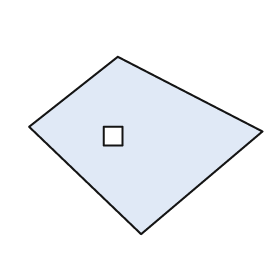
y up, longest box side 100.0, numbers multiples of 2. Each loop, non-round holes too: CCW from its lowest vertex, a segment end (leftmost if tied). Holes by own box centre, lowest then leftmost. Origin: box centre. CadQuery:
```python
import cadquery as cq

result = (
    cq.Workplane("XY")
    .moveTo(-2.0, -38.0)
    .lineTo(50.0, 6.0)
    .lineTo(-12.0, 38.0)
    .lineTo(-50.0, 8.0)
    .close()
    .moveTo(-18.0, 0.0)
    .lineTo(-10.0, 0.0)
    .lineTo(-10.0, 8.0)
    .lineTo(-18.0, 8.0)
    .close()
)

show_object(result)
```